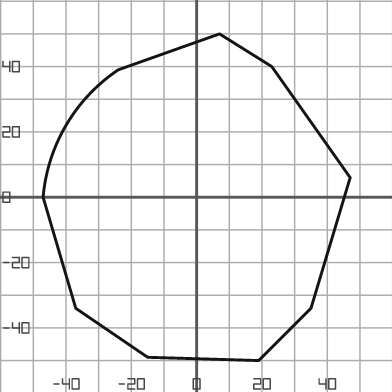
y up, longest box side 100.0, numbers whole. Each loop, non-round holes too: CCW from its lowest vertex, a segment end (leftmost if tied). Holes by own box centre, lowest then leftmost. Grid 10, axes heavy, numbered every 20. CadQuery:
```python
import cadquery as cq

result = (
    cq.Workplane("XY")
    .moveTo(19.0, -50.0)
    .lineTo(35.0, -34.0)
    .lineTo(47.0, 6.0)
    .lineTo(23.0, 40.0)
    .lineTo(7.0, 50.0)
    .lineTo(-24.0, 39.0)
    .threePointArc((-40.0, 22.0), (-47.0, 0.0))
    .lineTo(-37.0, -34.0)
    .lineTo(-15.0, -49.0)
    .close()
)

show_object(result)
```